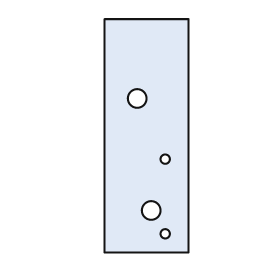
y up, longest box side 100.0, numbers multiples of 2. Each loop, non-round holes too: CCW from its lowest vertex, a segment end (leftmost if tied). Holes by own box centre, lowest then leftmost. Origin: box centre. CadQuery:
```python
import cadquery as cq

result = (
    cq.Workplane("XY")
    .moveTo(-18.0, -50.0)
    .lineTo(18.0, -50.0)
    .lineTo(18.0, 50.0)
    .lineTo(-18.0, 50.0)
    .close()
    .moveTo(8.0, -42.0)
    .circle(2.0)
    .moveTo(2.0, -32.0)
    .circle(4.0)
    .moveTo(8.0, -10.0)
    .circle(2.0)
    .moveTo(-4.0, 16.0)
    .circle(4.0)
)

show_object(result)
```